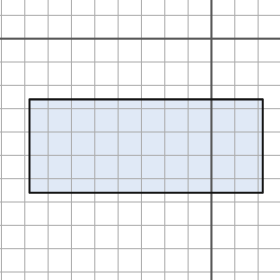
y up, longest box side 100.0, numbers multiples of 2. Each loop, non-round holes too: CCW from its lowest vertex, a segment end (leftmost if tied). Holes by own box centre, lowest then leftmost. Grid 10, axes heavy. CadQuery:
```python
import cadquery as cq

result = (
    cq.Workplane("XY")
    .moveTo(-78.0, -66.0)
    .lineTo(22.0, -66.0)
    .lineTo(22.0, -26.0)
    .lineTo(-78.0, -26.0)
    .close()
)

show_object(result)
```